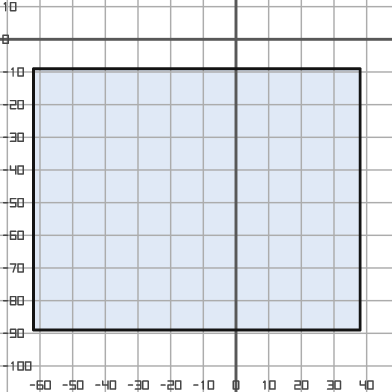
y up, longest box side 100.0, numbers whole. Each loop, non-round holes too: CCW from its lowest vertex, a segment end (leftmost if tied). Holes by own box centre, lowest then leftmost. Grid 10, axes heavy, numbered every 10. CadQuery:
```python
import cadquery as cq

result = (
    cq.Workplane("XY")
    .moveTo(-62.0, -89.0)
    .lineTo(38.0, -89.0)
    .lineTo(38.0, -9.0)
    .lineTo(-62.0, -9.0)
    .close()
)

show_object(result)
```